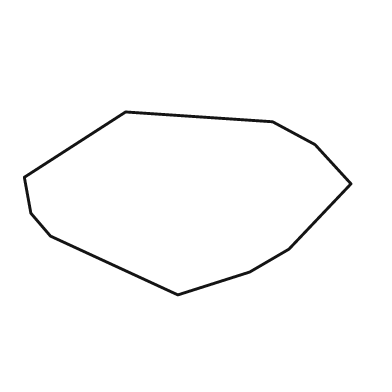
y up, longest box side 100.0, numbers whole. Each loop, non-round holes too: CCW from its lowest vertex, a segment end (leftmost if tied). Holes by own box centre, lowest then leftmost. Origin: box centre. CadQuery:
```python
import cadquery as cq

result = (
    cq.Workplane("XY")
    .moveTo(-3.0, -28.0)
    .lineTo(19.0, -21.0)
    .lineTo(31.0, -14.0)
    .lineTo(50.0, 6.0)
    .lineTo(39.0, 18.0)
    .lineTo(26.0, 25.0)
    .lineTo(-19.0, 28.0)
    .lineTo(-50.0, 8.0)
    .lineTo(-48.0, -3.0)
    .lineTo(-42.0, -10.0)
    .close()
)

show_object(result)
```